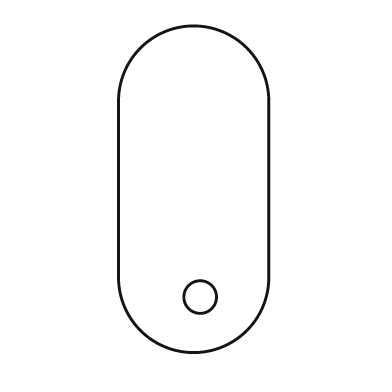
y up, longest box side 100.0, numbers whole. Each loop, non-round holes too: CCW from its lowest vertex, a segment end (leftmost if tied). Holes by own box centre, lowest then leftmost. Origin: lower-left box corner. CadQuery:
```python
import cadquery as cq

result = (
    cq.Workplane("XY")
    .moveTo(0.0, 23.0)
    .threePointArc((23.0, 0.0), (46.0, 23.0))
    .lineTo(46.0, 77.0)
    .threePointArc((23.0, 100.0), (0.0, 77.0))
    .close()
    .moveTo(25.0, 17.0)
    .circle(5.0)
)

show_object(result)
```